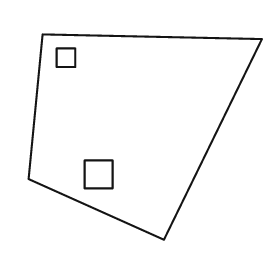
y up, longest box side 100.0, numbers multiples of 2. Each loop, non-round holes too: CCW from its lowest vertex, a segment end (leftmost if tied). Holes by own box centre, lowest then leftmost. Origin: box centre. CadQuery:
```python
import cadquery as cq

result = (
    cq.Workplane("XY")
    .moveTo(8.0, -44.0)
    .lineTo(50.0, 42.0)
    .lineTo(-44.0, 44.0)
    .lineTo(-50.0, -18.0)
    .close()
    .moveTo(-26.0, -22.0)
    .lineTo(-14.0, -22.0)
    .lineTo(-14.0, -10.0)
    .lineTo(-26.0, -10.0)
    .close()
    .moveTo(-38.0, 30.0)
    .lineTo(-30.0, 30.0)
    .lineTo(-30.0, 38.0)
    .lineTo(-38.0, 38.0)
    .close()
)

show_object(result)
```